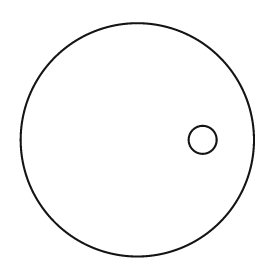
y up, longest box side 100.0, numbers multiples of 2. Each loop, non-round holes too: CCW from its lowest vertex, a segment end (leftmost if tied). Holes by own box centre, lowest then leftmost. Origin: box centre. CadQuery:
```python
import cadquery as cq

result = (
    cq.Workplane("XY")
    .moveTo(0.0, 0.0)
    .circle(50.0)
    .moveTo(28.0, 0.0)
    .circle(6.0)
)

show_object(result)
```